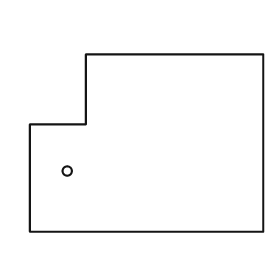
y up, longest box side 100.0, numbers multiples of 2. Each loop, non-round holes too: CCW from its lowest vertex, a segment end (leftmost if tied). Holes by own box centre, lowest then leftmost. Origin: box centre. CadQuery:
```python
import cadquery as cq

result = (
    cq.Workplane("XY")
    .moveTo(-50.0, -38.0)
    .lineTo(50.0, -38.0)
    .lineTo(50.0, 38.0)
    .lineTo(-26.0, 38.0)
    .lineTo(-26.0, 8.0)
    .lineTo(-50.0, 8.0)
    .close()
    .moveTo(-34.0, -12.0)
    .circle(2.0)
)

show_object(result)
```